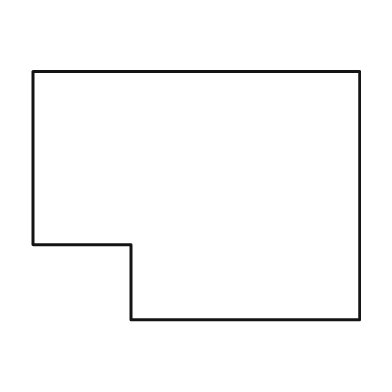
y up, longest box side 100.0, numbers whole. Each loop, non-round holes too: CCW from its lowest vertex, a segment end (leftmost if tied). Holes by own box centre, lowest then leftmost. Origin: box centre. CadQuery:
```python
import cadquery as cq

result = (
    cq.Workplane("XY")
    .moveTo(-20.0, -38.0)
    .lineTo(50.0, -38.0)
    .lineTo(50.0, 38.0)
    .lineTo(-50.0, 38.0)
    .lineTo(-50.0, -15.0)
    .lineTo(-20.0, -15.0)
    .close()
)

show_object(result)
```